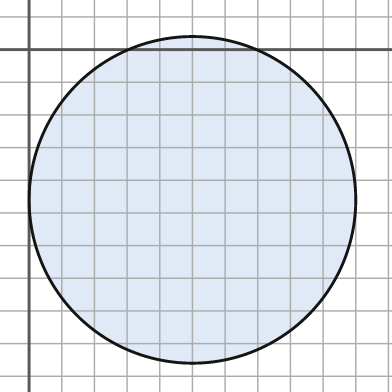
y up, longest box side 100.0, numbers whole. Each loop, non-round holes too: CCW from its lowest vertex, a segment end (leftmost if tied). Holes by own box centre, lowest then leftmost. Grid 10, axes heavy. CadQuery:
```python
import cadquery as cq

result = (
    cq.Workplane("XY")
    .moveTo(50.0, -46.0)
    .circle(50.0)
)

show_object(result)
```